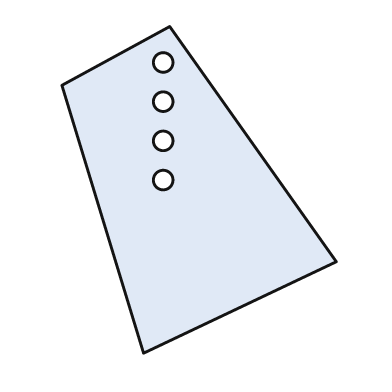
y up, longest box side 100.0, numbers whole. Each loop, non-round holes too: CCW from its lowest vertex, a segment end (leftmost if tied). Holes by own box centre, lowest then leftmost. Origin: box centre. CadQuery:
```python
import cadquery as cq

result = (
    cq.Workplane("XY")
    .moveTo(-17.0, -50.0)
    .lineTo(42.0, -22.0)
    .lineTo(-9.0, 50.0)
    .lineTo(-42.0, 32.0)
    .close()
    .moveTo(-11.0, 3.0)
    .circle(3.0)
    .moveTo(-11.0, 15.0)
    .circle(3.0)
    .moveTo(-11.0, 27.0)
    .circle(3.0)
    .moveTo(-11.0, 39.0)
    .circle(3.0)
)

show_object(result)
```